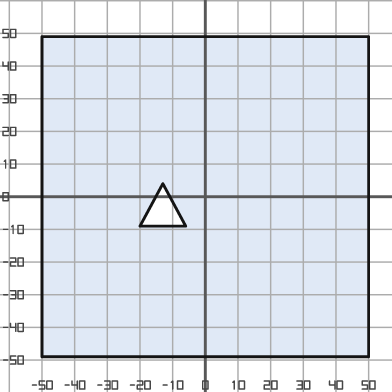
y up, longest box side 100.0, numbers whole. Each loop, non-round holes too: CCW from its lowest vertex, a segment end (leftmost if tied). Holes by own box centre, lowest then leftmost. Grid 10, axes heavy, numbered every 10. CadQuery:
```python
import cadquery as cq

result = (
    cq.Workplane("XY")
    .moveTo(-50.0, -49.0)
    .lineTo(50.0, -49.0)
    .lineTo(50.0, 49.0)
    .lineTo(-50.0, 49.0)
    .close()
    .moveTo(-20.0, -9.0)
    .lineTo(-6.0, -9.0)
    .lineTo(-13.0, 4.0)
    .close()
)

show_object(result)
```